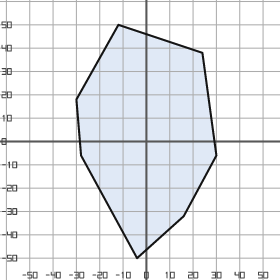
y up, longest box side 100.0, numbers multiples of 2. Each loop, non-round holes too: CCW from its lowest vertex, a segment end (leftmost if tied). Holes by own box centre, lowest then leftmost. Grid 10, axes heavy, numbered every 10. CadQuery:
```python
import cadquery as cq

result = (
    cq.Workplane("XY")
    .moveTo(-4.0, -50.0)
    .lineTo(16.0, -32.0)
    .lineTo(30.0, -6.0)
    .lineTo(24.0, 38.0)
    .lineTo(-12.0, 50.0)
    .lineTo(-30.0, 18.0)
    .lineTo(-28.0, -6.0)
    .close()
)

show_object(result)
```